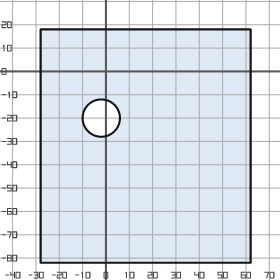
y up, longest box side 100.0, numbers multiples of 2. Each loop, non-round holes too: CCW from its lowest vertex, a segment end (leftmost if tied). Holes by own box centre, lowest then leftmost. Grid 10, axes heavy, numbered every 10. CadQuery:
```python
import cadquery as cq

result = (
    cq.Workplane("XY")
    .moveTo(-28.0, -82.0)
    .lineTo(62.0, -82.0)
    .lineTo(62.0, 18.0)
    .lineTo(-28.0, 18.0)
    .close()
    .moveTo(-2.0, -20.0)
    .circle(8.0)
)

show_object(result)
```